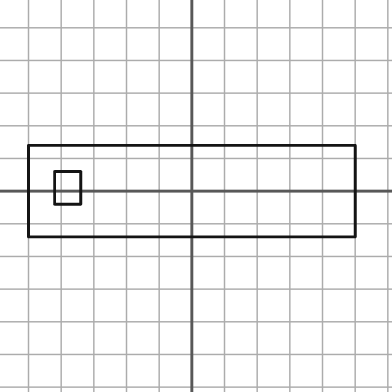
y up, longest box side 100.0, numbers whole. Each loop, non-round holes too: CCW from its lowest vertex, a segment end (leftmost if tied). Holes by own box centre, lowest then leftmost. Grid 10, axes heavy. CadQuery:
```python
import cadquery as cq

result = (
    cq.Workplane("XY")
    .moveTo(-50.0, -14.0)
    .lineTo(50.0, -14.0)
    .lineTo(50.0, 14.0)
    .lineTo(-50.0, 14.0)
    .close()
    .moveTo(-42.0, -4.0)
    .lineTo(-34.0, -4.0)
    .lineTo(-34.0, 6.0)
    .lineTo(-42.0, 6.0)
    .close()
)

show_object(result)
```